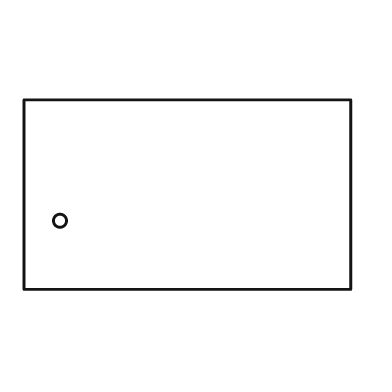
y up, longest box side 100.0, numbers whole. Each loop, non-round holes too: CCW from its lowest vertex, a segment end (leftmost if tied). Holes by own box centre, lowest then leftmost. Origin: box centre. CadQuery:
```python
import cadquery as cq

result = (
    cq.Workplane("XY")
    .moveTo(-50.0, -29.0)
    .lineTo(50.0, -29.0)
    .lineTo(50.0, 29.0)
    .lineTo(-50.0, 29.0)
    .close()
    .moveTo(-39.0, -8.0)
    .circle(2.0)
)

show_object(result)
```